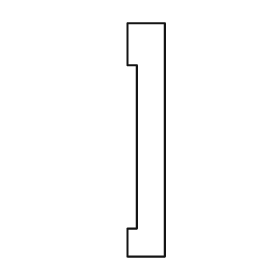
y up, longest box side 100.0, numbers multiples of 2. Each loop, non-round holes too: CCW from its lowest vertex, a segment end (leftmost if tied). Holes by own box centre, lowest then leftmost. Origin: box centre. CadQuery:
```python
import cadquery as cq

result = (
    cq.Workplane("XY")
    .moveTo(-8.0, -50.0)
    .lineTo(8.0, -50.0)
    .lineTo(8.0, 50.0)
    .lineTo(-8.0, 50.0)
    .lineTo(-8.0, 32.0)
    .lineTo(-4.0, 32.0)
    .lineTo(-4.0, -38.0)
    .lineTo(-8.0, -38.0)
    .close()
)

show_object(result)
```